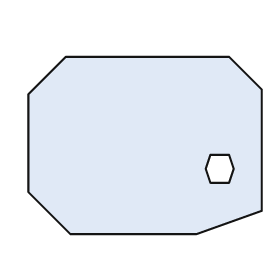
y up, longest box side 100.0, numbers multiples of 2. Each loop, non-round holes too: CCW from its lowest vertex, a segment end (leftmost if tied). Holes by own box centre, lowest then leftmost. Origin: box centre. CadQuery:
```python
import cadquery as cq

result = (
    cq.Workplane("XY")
    .moveTo(-32.0, -38.0)
    .lineTo(22.0, -38.0)
    .lineTo(50.0, -28.0)
    .lineTo(50.0, 24.0)
    .lineTo(36.0, 38.0)
    .lineTo(-34.0, 38.0)
    .lineTo(-50.0, 22.0)
    .lineTo(-50.0, -20.0)
    .close()
    .moveTo(28.0, -16.0)
    .lineTo(36.0, -16.0)
    .lineTo(38.0, -10.0)
    .lineTo(36.0, -4.0)
    .lineTo(28.0, -4.0)
    .lineTo(26.0, -10.0)
    .close()
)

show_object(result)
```